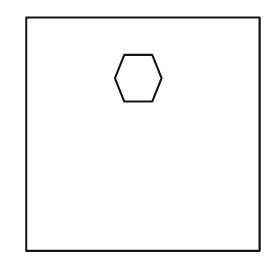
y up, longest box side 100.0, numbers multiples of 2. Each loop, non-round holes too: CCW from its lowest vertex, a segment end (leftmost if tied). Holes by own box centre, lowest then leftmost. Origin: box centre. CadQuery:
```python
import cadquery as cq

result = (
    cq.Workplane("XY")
    .moveTo(-50.0, -50.0)
    .lineTo(50.0, -50.0)
    .lineTo(50.0, 50.0)
    .lineTo(-50.0, 50.0)
    .close()
    .moveTo(-8.0, 14.0)
    .lineTo(4.0, 14.0)
    .lineTo(8.0, 24.0)
    .lineTo(4.0, 34.0)
    .lineTo(-8.0, 34.0)
    .lineTo(-12.0, 24.0)
    .close()
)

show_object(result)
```